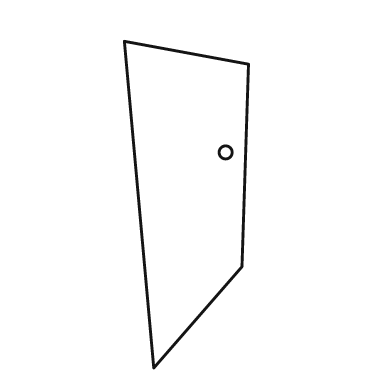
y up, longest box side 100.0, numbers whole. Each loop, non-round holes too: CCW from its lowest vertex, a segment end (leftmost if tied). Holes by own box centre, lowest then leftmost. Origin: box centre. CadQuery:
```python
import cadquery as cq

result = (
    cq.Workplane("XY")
    .moveTo(-10.0, -50.0)
    .lineTo(17.0, -19.0)
    .lineTo(19.0, 43.0)
    .lineTo(-19.0, 50.0)
    .close()
    .moveTo(12.0, 16.0)
    .circle(2.0)
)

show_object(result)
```